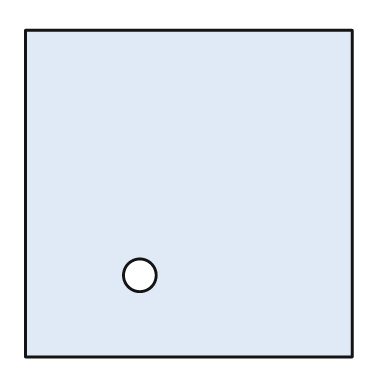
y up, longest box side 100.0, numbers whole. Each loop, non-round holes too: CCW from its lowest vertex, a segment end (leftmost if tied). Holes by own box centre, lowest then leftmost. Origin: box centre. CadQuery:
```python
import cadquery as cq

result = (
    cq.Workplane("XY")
    .moveTo(-50.0, -50.0)
    .lineTo(50.0, -50.0)
    .lineTo(50.0, 50.0)
    .lineTo(-50.0, 50.0)
    .close()
    .moveTo(-15.0, -25.0)
    .circle(5.0)
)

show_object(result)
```